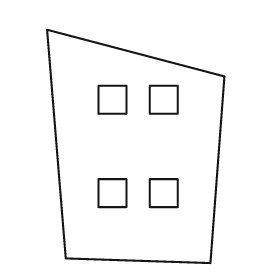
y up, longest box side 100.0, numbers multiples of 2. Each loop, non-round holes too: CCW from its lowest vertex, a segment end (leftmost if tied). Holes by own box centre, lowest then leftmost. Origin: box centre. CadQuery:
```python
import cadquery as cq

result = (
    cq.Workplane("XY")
    .moveTo(32.0, -50.0)
    .lineTo(38.0, 30.0)
    .lineTo(-38.0, 50.0)
    .lineTo(-30.0, -48.0)
    .close()
    .moveTo(-16.0, -26.0)
    .lineTo(-4.0, -26.0)
    .lineTo(-4.0, -14.0)
    .lineTo(-16.0, -14.0)
    .close()
    .moveTo(6.0, -26.0)
    .lineTo(18.0, -26.0)
    .lineTo(18.0, -14.0)
    .lineTo(6.0, -14.0)
    .close()
    .moveTo(-16.0, 14.0)
    .lineTo(-4.0, 14.0)
    .lineTo(-4.0, 26.0)
    .lineTo(-16.0, 26.0)
    .close()
    .moveTo(6.0, 14.0)
    .lineTo(18.0, 14.0)
    .lineTo(18.0, 26.0)
    .lineTo(6.0, 26.0)
    .close()
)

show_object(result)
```